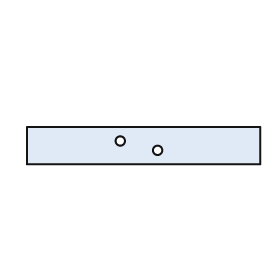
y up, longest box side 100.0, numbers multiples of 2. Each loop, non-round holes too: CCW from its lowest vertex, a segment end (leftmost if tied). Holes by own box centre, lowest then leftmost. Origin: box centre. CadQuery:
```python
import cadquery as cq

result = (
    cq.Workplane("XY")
    .moveTo(-50.0, -8.0)
    .lineTo(50.0, -8.0)
    .lineTo(50.0, 8.0)
    .lineTo(-50.0, 8.0)
    .close()
    .moveTo(6.0, -2.0)
    .circle(2.0)
    .moveTo(-10.0, 2.0)
    .circle(2.0)
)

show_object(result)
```